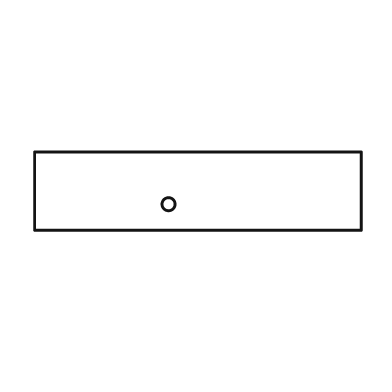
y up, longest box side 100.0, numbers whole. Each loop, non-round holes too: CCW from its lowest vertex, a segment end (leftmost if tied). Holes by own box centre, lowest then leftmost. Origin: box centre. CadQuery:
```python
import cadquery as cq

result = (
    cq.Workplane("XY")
    .moveTo(-50.0, -12.0)
    .lineTo(50.0, -12.0)
    .lineTo(50.0, 12.0)
    .lineTo(-50.0, 12.0)
    .close()
    .moveTo(-9.0, -4.0)
    .circle(2.0)
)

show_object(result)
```